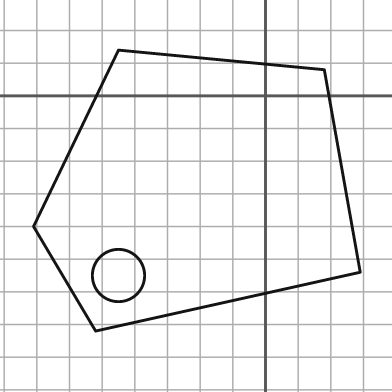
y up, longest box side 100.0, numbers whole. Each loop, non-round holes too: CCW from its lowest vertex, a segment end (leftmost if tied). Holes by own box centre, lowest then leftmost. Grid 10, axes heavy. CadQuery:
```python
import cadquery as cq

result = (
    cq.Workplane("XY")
    .moveTo(-52.0, -72.0)
    .lineTo(29.0, -54.0)
    .lineTo(18.0, 8.0)
    .lineTo(-45.0, 14.0)
    .lineTo(-71.0, -40.0)
    .close()
    .moveTo(-45.0, -55.0)
    .circle(8.0)
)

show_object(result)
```